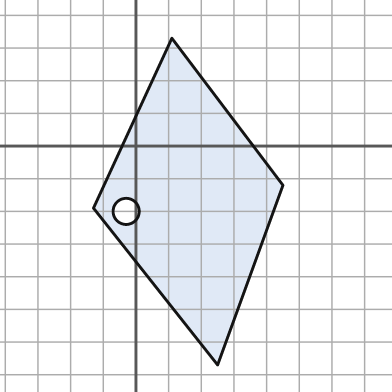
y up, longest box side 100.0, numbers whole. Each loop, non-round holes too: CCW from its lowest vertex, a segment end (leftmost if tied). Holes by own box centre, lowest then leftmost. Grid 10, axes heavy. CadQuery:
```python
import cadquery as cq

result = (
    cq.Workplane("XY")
    .moveTo(25.0, -67.0)
    .lineTo(45.0, -12.0)
    .lineTo(11.0, 33.0)
    .lineTo(-13.0, -19.0)
    .close()
    .moveTo(-3.0, -20.0)
    .circle(4.0)
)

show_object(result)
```